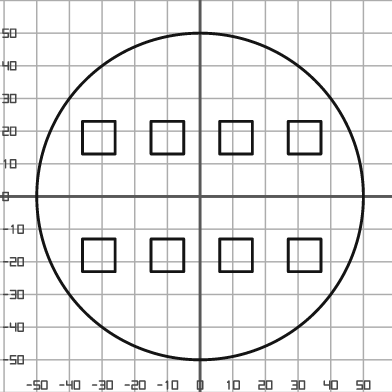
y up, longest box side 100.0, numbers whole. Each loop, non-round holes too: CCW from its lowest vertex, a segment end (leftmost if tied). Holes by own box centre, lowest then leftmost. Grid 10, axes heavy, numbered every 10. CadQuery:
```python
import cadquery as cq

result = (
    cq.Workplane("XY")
    .moveTo(0.0, 0.0)
    .circle(50.0)
    .moveTo(-36.0, -23.0)
    .lineTo(-26.0, -23.0)
    .lineTo(-26.0, -13.0)
    .lineTo(-36.0, -13.0)
    .close()
    .moveTo(-15.0, -23.0)
    .lineTo(-5.0, -23.0)
    .lineTo(-5.0, -13.0)
    .lineTo(-15.0, -13.0)
    .close()
    .moveTo(6.0, -23.0)
    .lineTo(16.0, -23.0)
    .lineTo(16.0, -13.0)
    .lineTo(6.0, -13.0)
    .close()
    .moveTo(27.0, -23.0)
    .lineTo(37.0, -23.0)
    .lineTo(37.0, -13.0)
    .lineTo(27.0, -13.0)
    .close()
    .moveTo(-36.0, 13.0)
    .lineTo(-26.0, 13.0)
    .lineTo(-26.0, 23.0)
    .lineTo(-36.0, 23.0)
    .close()
    .moveTo(-15.0, 13.0)
    .lineTo(-5.0, 13.0)
    .lineTo(-5.0, 23.0)
    .lineTo(-15.0, 23.0)
    .close()
    .moveTo(6.0, 13.0)
    .lineTo(16.0, 13.0)
    .lineTo(16.0, 23.0)
    .lineTo(6.0, 23.0)
    .close()
    .moveTo(27.0, 13.0)
    .lineTo(37.0, 13.0)
    .lineTo(37.0, 23.0)
    .lineTo(27.0, 23.0)
    .close()
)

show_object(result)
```